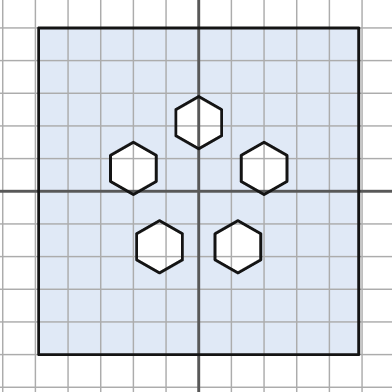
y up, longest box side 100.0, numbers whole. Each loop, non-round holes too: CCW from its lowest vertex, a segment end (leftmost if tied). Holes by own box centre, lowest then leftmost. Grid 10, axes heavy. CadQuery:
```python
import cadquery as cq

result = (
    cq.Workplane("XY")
    .moveTo(-49.0, -50.0)
    .lineTo(49.0, -50.0)
    .lineTo(49.0, 50.0)
    .lineTo(-49.0, 50.0)
    .close()
    .moveTo(-12.0, -25.0)
    .lineTo(-5.0, -21.0)
    .lineTo(-5.0, -13.0)
    .lineTo(-12.0, -9.0)
    .lineTo(-19.0, -13.0)
    .lineTo(-19.0, -21.0)
    .close()
    .moveTo(12.0, -25.0)
    .lineTo(19.0, -21.0)
    .lineTo(19.0, -13.0)
    .lineTo(12.0, -9.0)
    .lineTo(5.0, -13.0)
    .lineTo(5.0, -21.0)
    .close()
    .moveTo(-20.0, -1.0)
    .lineTo(-13.0, 3.0)
    .lineTo(-13.0, 11.0)
    .lineTo(-20.0, 15.0)
    .lineTo(-27.0, 11.0)
    .lineTo(-27.0, 3.0)
    .close()
    .moveTo(20.0, -1.0)
    .lineTo(27.0, 3.0)
    .lineTo(27.0, 11.0)
    .lineTo(20.0, 15.0)
    .lineTo(13.0, 11.0)
    .lineTo(13.0, 3.0)
    .close()
    .moveTo(0.0, 13.0)
    .lineTo(7.0, 17.0)
    .lineTo(7.0, 25.0)
    .lineTo(0.0, 29.0)
    .lineTo(-7.0, 25.0)
    .lineTo(-7.0, 17.0)
    .close()
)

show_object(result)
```